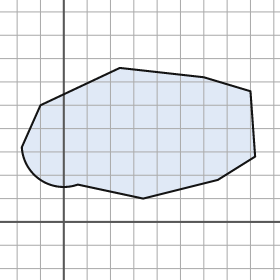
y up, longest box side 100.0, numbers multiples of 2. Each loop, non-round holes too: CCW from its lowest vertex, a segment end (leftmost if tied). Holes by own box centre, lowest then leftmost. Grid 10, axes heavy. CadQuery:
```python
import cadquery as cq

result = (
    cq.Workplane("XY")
    .moveTo(34.0, 10.0)
    .lineTo(66.0, 18.0)
    .lineTo(82.0, 28.0)
    .lineTo(80.0, 56.0)
    .lineTo(60.0, 62.0)
    .lineTo(24.0, 66.0)
    .lineTo(-10.0, 50.0)
    .lineTo(-18.0, 32.0)
    .threePointArc((-10.0, 18.0), (6.0, 16.0))
    .close()
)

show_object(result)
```